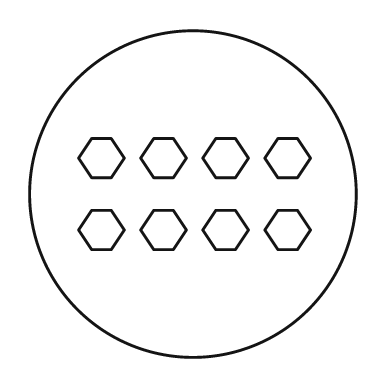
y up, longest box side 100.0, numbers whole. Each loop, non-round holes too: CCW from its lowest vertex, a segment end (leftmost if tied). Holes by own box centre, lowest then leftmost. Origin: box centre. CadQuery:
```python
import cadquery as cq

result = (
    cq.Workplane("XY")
    .moveTo(0.0, 0.0)
    .circle(50.0)
    .moveTo(-31.0, -17.0)
    .lineTo(-25.0, -17.0)
    .lineTo(-21.0, -11.0)
    .lineTo(-25.0, -5.0)
    .lineTo(-31.0, -5.0)
    .lineTo(-35.0, -11.0)
    .close()
    .moveTo(-12.0, -17.0)
    .lineTo(-6.0, -17.0)
    .lineTo(-2.0, -11.0)
    .lineTo(-6.0, -5.0)
    .lineTo(-12.0, -5.0)
    .lineTo(-16.0, -11.0)
    .close()
    .moveTo(7.0, -17.0)
    .lineTo(13.0, -17.0)
    .lineTo(17.0, -11.0)
    .lineTo(13.0, -5.0)
    .lineTo(7.0, -5.0)
    .lineTo(3.0, -11.0)
    .close()
    .moveTo(26.0, -17.0)
    .lineTo(32.0, -17.0)
    .lineTo(36.0, -11.0)
    .lineTo(32.0, -5.0)
    .lineTo(26.0, -5.0)
    .lineTo(22.0, -11.0)
    .close()
    .moveTo(-31.0, 5.0)
    .lineTo(-25.0, 5.0)
    .lineTo(-21.0, 11.0)
    .lineTo(-25.0, 17.0)
    .lineTo(-31.0, 17.0)
    .lineTo(-35.0, 11.0)
    .close()
    .moveTo(-12.0, 5.0)
    .lineTo(-6.0, 5.0)
    .lineTo(-2.0, 11.0)
    .lineTo(-6.0, 17.0)
    .lineTo(-12.0, 17.0)
    .lineTo(-16.0, 11.0)
    .close()
    .moveTo(7.0, 5.0)
    .lineTo(13.0, 5.0)
    .lineTo(17.0, 11.0)
    .lineTo(13.0, 17.0)
    .lineTo(7.0, 17.0)
    .lineTo(3.0, 11.0)
    .close()
    .moveTo(26.0, 5.0)
    .lineTo(32.0, 5.0)
    .lineTo(36.0, 11.0)
    .lineTo(32.0, 17.0)
    .lineTo(26.0, 17.0)
    .lineTo(22.0, 11.0)
    .close()
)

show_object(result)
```